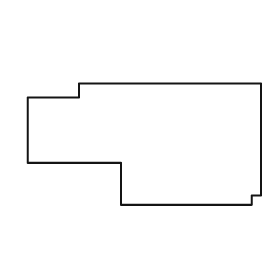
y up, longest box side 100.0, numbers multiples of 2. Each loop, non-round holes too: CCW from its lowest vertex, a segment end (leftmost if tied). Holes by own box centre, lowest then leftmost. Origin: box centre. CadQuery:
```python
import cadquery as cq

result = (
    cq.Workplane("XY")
    .moveTo(-10.0, -26.0)
    .lineTo(46.0, -26.0)
    .lineTo(46.0, -22.0)
    .lineTo(50.0, -22.0)
    .lineTo(50.0, 26.0)
    .lineTo(-28.0, 26.0)
    .lineTo(-28.0, 20.0)
    .lineTo(-50.0, 20.0)
    .lineTo(-50.0, -8.0)
    .lineTo(-10.0, -8.0)
    .close()
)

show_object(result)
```